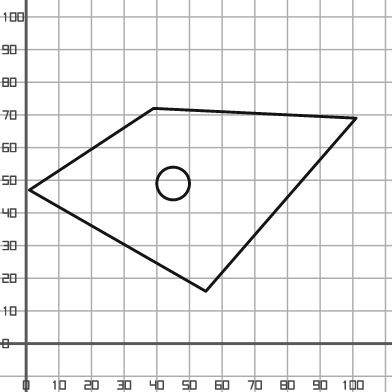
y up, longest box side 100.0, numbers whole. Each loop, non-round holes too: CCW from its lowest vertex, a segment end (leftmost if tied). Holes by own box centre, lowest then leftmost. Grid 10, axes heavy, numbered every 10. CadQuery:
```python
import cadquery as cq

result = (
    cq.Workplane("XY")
    .moveTo(55.0, 16.0)
    .lineTo(101.0, 69.0)
    .lineTo(39.0, 72.0)
    .lineTo(1.0, 47.0)
    .close()
    .moveTo(45.0, 49.0)
    .circle(5.0)
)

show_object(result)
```